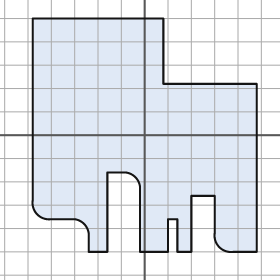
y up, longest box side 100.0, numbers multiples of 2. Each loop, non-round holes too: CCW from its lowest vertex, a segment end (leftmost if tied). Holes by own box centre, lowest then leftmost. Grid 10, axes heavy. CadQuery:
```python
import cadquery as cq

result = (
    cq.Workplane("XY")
    .moveTo(-24.0, -50.0)
    .lineTo(-16.0, -50.0)
    .lineTo(-16.0, -16.0)
    .lineTo(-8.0, -16.0)
    .threePointArc((-4.0, -18.0), (-2.0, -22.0))
    .lineTo(-2.0, -50.0)
    .lineTo(10.0, -50.0)
    .lineTo(10.0, -36.0)
    .lineTo(14.0, -36.0)
    .lineTo(14.0, -50.0)
    .lineTo(20.0, -50.0)
    .lineTo(20.0, -26.0)
    .lineTo(30.0, -26.0)
    .lineTo(30.0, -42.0)
    .threePointArc((32.0, -48.0), (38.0, -50.0))
    .lineTo(48.0, -50.0)
    .lineTo(48.0, 22.0)
    .lineTo(8.0, 22.0)
    .lineTo(8.0, 50.0)
    .lineTo(-48.0, 50.0)
    .lineTo(-48.0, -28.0)
    .threePointArc((-46.0, -34.0), (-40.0, -36.0))
    .lineTo(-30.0, -36.0)
    .threePointArc((-26.0, -38.0), (-24.0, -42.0))
    .close()
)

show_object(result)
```